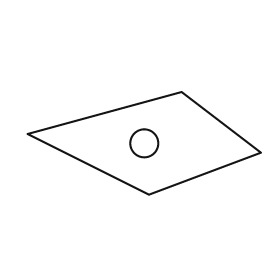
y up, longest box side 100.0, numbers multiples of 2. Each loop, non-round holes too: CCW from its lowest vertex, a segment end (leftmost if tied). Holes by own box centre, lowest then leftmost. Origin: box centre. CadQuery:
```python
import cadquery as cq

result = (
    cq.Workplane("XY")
    .moveTo(2.0, -22.0)
    .lineTo(50.0, -4.0)
    .lineTo(16.0, 22.0)
    .lineTo(-50.0, 4.0)
    .close()
    .moveTo(0.0, 0.0)
    .circle(6.0)
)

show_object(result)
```